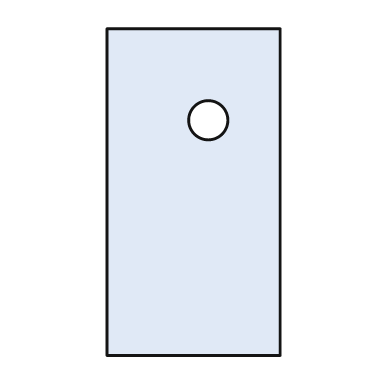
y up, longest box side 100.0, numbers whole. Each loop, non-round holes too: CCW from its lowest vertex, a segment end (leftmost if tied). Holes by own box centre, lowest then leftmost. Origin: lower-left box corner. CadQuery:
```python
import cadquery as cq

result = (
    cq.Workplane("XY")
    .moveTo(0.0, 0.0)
    .lineTo(53.0, 0.0)
    .lineTo(53.0, 100.0)
    .lineTo(0.0, 100.0)
    .close()
    .moveTo(31.0, 72.0)
    .circle(6.0)
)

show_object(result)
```